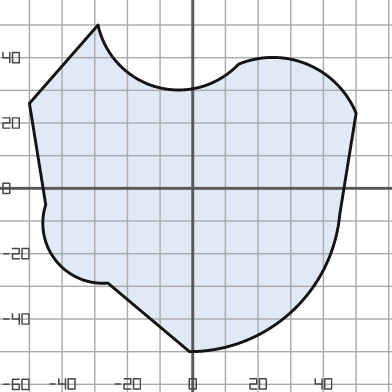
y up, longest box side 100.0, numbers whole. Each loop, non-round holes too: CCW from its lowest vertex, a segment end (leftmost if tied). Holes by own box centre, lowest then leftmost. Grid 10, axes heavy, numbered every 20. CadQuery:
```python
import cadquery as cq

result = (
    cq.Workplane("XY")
    .moveTo(-1.0, -50.0)
    .threePointArc((30.0, -38.0), (45.0, -8.0))
    .lineTo(50.0, 23.0)
    .threePointArc((35.0, 38.0), (14.0, 38.0))
    .threePointArc((-11.0, 31.0), (-29.0, 50.0))
    .lineTo(-50.0, 26.0)
    .lineTo(-45.0, -5.0)
    .threePointArc((-42.0, -22.0), (-26.0, -29.0))
    .close()
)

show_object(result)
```